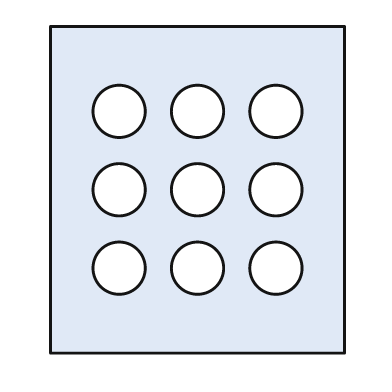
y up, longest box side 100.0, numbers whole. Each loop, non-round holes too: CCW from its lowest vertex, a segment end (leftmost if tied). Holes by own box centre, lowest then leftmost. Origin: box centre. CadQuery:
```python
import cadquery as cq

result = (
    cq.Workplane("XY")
    .moveTo(-45.0, -50.0)
    .lineTo(45.0, -50.0)
    .lineTo(45.0, 50.0)
    .lineTo(-45.0, 50.0)
    .close()
    .moveTo(-24.0, -24.0)
    .circle(8.0)
    .moveTo(0.0, -24.0)
    .circle(8.0)
    .moveTo(24.0, -24.0)
    .circle(8.0)
    .moveTo(-24.0, 0.0)
    .circle(8.0)
    .moveTo(0.0, 0.0)
    .circle(8.0)
    .moveTo(24.0, 0.0)
    .circle(8.0)
    .moveTo(-24.0, 24.0)
    .circle(8.0)
    .moveTo(0.0, 24.0)
    .circle(8.0)
    .moveTo(24.0, 24.0)
    .circle(8.0)
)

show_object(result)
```